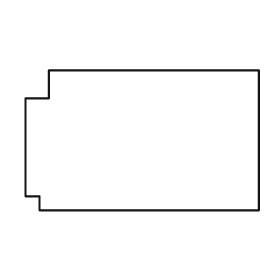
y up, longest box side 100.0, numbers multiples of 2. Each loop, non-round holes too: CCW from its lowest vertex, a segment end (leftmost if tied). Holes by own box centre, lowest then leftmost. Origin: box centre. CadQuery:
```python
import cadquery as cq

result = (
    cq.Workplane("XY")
    .moveTo(-44.0, -30.0)
    .lineTo(50.0, -30.0)
    .lineTo(50.0, 30.0)
    .lineTo(-40.0, 30.0)
    .lineTo(-40.0, 18.0)
    .lineTo(-50.0, 18.0)
    .lineTo(-50.0, -24.0)
    .lineTo(-44.0, -24.0)
    .close()
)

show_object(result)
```